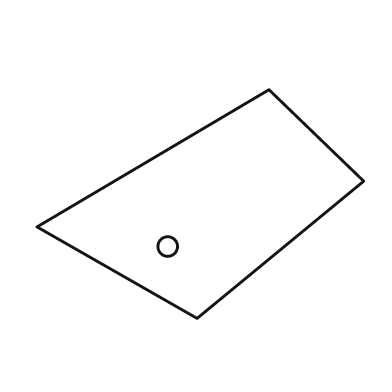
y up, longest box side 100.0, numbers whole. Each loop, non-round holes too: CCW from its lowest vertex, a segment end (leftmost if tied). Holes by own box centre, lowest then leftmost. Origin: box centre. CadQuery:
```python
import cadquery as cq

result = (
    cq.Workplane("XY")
    .moveTo(-1.0, -35.0)
    .lineTo(50.0, 7.0)
    .lineTo(21.0, 35.0)
    .lineTo(-50.0, -7.0)
    .close()
    .moveTo(-10.0, -13.0)
    .circle(3.0)
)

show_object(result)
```